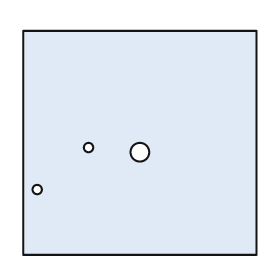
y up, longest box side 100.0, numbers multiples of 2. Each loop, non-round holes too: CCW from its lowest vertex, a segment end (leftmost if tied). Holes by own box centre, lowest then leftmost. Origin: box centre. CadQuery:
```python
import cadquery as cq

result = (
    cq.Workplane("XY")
    .moveTo(-50.0, -48.0)
    .lineTo(50.0, -48.0)
    .lineTo(50.0, 48.0)
    .lineTo(-50.0, 48.0)
    .close()
    .moveTo(-44.0, -20.0)
    .circle(2.0)
    .moveTo(0.0, -4.0)
    .circle(4.0)
    .moveTo(-22.0, -2.0)
    .circle(2.0)
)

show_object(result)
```